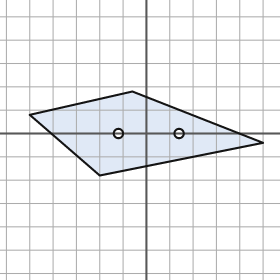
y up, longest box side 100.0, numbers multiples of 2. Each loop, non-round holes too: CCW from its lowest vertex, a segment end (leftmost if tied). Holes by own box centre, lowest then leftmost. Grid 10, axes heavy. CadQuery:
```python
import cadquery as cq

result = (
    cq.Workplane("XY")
    .moveTo(-20.0, -18.0)
    .lineTo(50.0, -4.0)
    .lineTo(-6.0, 18.0)
    .lineTo(-50.0, 8.0)
    .close()
    .moveTo(-12.0, 0.0)
    .circle(2.0)
    .moveTo(14.0, 0.0)
    .circle(2.0)
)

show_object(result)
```